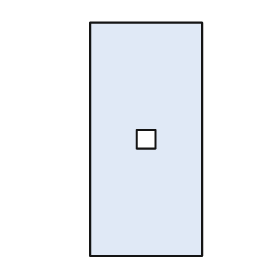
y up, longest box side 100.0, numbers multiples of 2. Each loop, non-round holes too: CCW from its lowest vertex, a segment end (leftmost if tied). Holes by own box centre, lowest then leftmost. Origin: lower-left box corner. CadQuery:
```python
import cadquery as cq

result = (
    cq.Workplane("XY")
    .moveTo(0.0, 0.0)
    .lineTo(48.0, 0.0)
    .lineTo(48.0, 100.0)
    .lineTo(0.0, 100.0)
    .close()
    .moveTo(20.0, 46.0)
    .lineTo(28.0, 46.0)
    .lineTo(28.0, 54.0)
    .lineTo(20.0, 54.0)
    .close()
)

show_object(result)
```